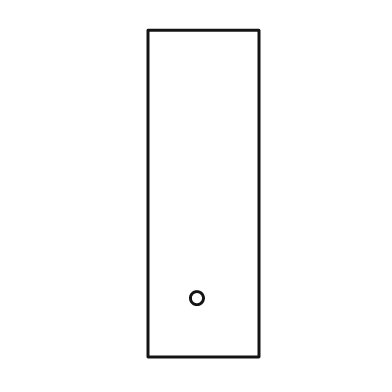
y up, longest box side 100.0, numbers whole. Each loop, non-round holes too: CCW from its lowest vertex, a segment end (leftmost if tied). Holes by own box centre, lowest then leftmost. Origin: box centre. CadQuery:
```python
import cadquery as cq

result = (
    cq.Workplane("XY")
    .moveTo(-17.0, -50.0)
    .lineTo(17.0, -50.0)
    .lineTo(17.0, 50.0)
    .lineTo(-17.0, 50.0)
    .close()
    .moveTo(-2.0, -32.0)
    .circle(2.0)
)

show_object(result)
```